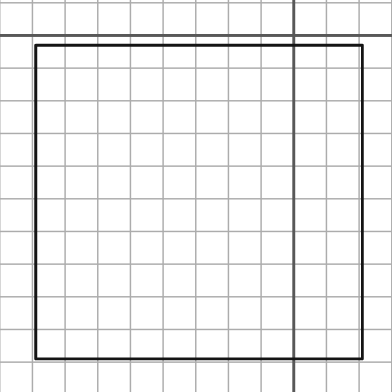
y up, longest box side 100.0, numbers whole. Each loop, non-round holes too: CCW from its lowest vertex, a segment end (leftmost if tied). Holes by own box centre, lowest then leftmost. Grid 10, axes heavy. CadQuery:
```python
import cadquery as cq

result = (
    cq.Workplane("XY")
    .moveTo(-79.0, -99.0)
    .lineTo(21.0, -99.0)
    .lineTo(21.0, -3.0)
    .lineTo(-79.0, -3.0)
    .close()
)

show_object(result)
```